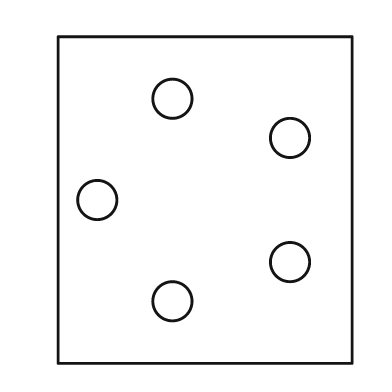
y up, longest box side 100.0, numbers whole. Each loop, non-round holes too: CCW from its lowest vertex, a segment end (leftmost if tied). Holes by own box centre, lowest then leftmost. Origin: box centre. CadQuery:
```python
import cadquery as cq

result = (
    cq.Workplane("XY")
    .moveTo(-45.0, -50.0)
    .lineTo(45.0, -50.0)
    .lineTo(45.0, 50.0)
    .lineTo(-45.0, 50.0)
    .close()
    .moveTo(-10.0, -31.0)
    .circle(6.0)
    .moveTo(26.0, -19.0)
    .circle(6.0)
    .moveTo(-33.0, 0.0)
    .circle(6.0)
    .moveTo(26.0, 19.0)
    .circle(6.0)
    .moveTo(-10.0, 31.0)
    .circle(6.0)
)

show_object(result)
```